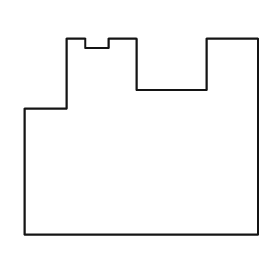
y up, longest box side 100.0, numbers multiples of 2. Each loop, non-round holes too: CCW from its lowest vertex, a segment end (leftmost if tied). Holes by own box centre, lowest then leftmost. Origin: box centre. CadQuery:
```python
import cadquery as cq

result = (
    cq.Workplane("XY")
    .moveTo(-50.0, -42.0)
    .lineTo(50.0, -42.0)
    .lineTo(50.0, 42.0)
    .lineTo(28.0, 42.0)
    .lineTo(28.0, 20.0)
    .lineTo(-2.0, 20.0)
    .lineTo(-2.0, 42.0)
    .lineTo(-14.0, 42.0)
    .lineTo(-14.0, 38.0)
    .lineTo(-24.0, 38.0)
    .lineTo(-24.0, 42.0)
    .lineTo(-32.0, 42.0)
    .lineTo(-32.0, 12.0)
    .lineTo(-50.0, 12.0)
    .close()
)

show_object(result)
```